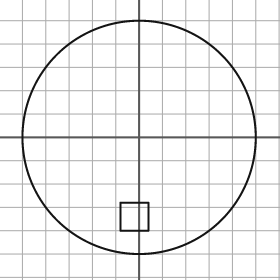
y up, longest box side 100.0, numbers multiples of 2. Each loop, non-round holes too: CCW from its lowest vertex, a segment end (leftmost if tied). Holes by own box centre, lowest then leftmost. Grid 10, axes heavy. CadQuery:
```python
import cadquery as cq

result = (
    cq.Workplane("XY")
    .moveTo(0.0, 0.0)
    .circle(50.0)
    .moveTo(-8.0, -40.0)
    .lineTo(4.0, -40.0)
    .lineTo(4.0, -28.0)
    .lineTo(-8.0, -28.0)
    .close()
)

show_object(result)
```